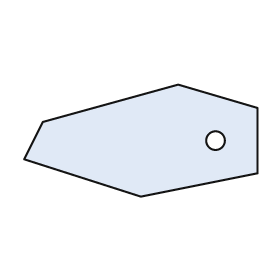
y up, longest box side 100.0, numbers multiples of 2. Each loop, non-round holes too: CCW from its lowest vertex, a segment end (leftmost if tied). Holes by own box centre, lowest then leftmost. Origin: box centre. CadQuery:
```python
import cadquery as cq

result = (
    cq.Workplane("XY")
    .moveTo(0.0, -24.0)
    .lineTo(50.0, -14.0)
    .lineTo(50.0, 14.0)
    .lineTo(16.0, 24.0)
    .lineTo(-42.0, 8.0)
    .lineTo(-50.0, -8.0)
    .close()
    .moveTo(32.0, 0.0)
    .circle(4.0)
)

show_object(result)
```